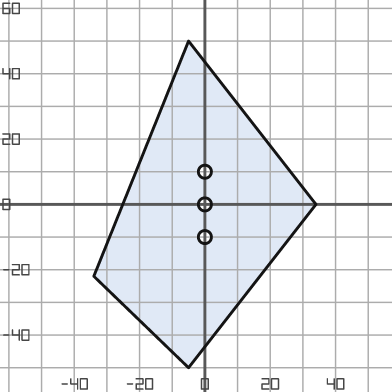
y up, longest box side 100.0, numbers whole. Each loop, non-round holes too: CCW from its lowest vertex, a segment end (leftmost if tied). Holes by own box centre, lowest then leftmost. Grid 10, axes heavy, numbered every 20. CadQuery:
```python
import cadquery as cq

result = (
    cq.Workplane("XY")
    .moveTo(-5.0, -50.0)
    .lineTo(34.0, 0.0)
    .lineTo(-5.0, 50.0)
    .lineTo(-34.0, -22.0)
    .close()
    .moveTo(0.0, -10.0)
    .circle(2.0)
    .moveTo(0.0, 0.0)
    .circle(2.0)
    .moveTo(0.0, 10.0)
    .circle(2.0)
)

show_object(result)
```